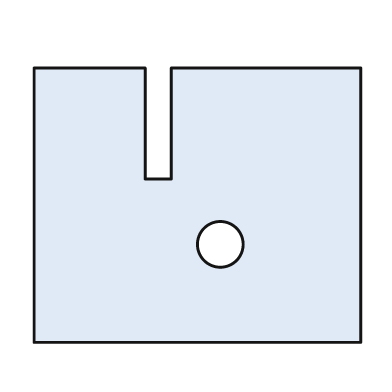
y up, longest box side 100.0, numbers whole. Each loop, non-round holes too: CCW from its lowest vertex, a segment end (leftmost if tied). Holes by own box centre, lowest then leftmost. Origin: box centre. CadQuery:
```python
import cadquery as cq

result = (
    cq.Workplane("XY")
    .moveTo(-50.0, -42.0)
    .lineTo(50.0, -42.0)
    .lineTo(50.0, 42.0)
    .lineTo(-8.0, 42.0)
    .lineTo(-8.0, 8.0)
    .lineTo(-16.0, 8.0)
    .lineTo(-16.0, 42.0)
    .lineTo(-50.0, 42.0)
    .close()
    .moveTo(7.0, -12.0)
    .circle(7.0)
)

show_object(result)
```